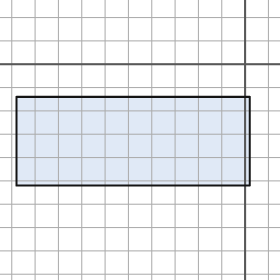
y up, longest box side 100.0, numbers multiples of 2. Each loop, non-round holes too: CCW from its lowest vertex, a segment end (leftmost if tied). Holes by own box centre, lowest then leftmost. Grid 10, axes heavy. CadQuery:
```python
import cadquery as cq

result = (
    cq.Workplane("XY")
    .moveTo(-98.0, -52.0)
    .lineTo(2.0, -52.0)
    .lineTo(2.0, -14.0)
    .lineTo(-98.0, -14.0)
    .close()
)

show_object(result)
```